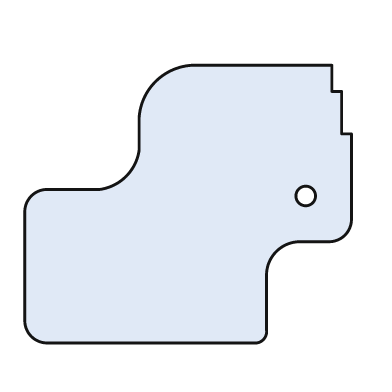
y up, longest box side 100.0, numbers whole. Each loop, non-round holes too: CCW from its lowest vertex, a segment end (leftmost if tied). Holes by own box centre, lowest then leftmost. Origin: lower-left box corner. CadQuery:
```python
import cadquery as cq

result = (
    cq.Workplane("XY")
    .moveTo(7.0, 0.0)
    .lineTo(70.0, 0.0)
    .threePointArc((73.0, 1.0), (74.0, 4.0))
    .lineTo(74.0, 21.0)
    .threePointArc((77.0, 28.0), (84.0, 31.0))
    .lineTo(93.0, 31.0)
    .threePointArc((98.0, 33.0), (100.0, 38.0))
    .lineTo(100.0, 64.0)
    .lineTo(97.0, 64.0)
    .lineTo(97.0, 77.0)
    .lineTo(94.0, 77.0)
    .lineTo(94.0, 85.0)
    .lineTo(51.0, 85.0)
    .threePointArc((40.0, 80.0), (35.0, 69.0))
    .lineTo(35.0, 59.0)
    .threePointArc((31.0, 51.0), (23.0, 47.0))
    .lineTo(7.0, 47.0)
    .threePointArc((2.0, 45.0), (0.0, 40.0))
    .lineTo(0.0, 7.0)
    .threePointArc((2.0, 2.0), (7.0, 0.0))
    .close()
    .moveTo(86.0, 45.0)
    .circle(3.0)
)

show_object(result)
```